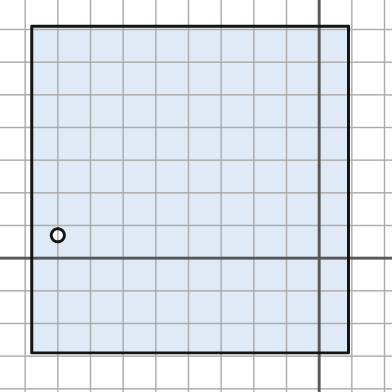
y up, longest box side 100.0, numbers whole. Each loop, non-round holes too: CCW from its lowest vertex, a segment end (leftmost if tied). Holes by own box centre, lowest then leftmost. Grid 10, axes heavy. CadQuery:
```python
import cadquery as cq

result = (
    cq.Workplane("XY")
    .moveTo(-88.0, -29.0)
    .lineTo(9.0, -29.0)
    .lineTo(9.0, 71.0)
    .lineTo(-88.0, 71.0)
    .close()
    .moveTo(-80.0, 7.0)
    .circle(2.0)
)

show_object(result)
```